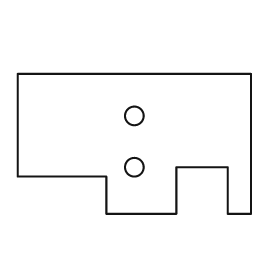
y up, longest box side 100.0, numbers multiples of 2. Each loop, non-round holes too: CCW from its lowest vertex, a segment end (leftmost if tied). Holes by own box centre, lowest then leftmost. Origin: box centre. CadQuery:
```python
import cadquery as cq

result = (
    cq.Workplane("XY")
    .moveTo(-12.0, -30.0)
    .lineTo(18.0, -30.0)
    .lineTo(18.0, -10.0)
    .lineTo(40.0, -10.0)
    .lineTo(40.0, -30.0)
    .lineTo(50.0, -30.0)
    .lineTo(50.0, 30.0)
    .lineTo(-50.0, 30.0)
    .lineTo(-50.0, -14.0)
    .lineTo(-12.0, -14.0)
    .close()
    .moveTo(0.0, -10.0)
    .circle(4.0)
    .moveTo(0.0, 12.0)
    .circle(4.0)
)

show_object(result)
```